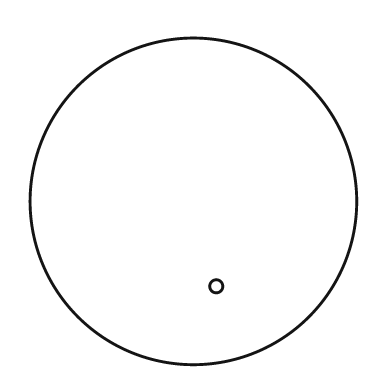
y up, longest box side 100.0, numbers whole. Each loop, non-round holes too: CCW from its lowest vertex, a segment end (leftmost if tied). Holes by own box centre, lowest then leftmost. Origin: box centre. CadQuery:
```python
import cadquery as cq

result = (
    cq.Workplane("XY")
    .moveTo(0.0, 0.0)
    .circle(50.0)
    .moveTo(7.0, -26.0)
    .circle(2.0)
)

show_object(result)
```